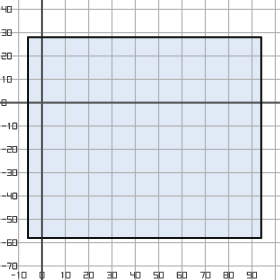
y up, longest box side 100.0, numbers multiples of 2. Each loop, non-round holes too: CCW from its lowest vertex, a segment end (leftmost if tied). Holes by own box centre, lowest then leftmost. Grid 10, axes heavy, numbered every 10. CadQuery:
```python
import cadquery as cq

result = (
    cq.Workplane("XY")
    .moveTo(-6.0, -58.0)
    .lineTo(94.0, -58.0)
    .lineTo(94.0, 28.0)
    .lineTo(-6.0, 28.0)
    .close()
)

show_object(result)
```